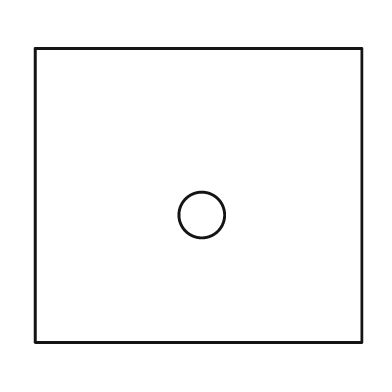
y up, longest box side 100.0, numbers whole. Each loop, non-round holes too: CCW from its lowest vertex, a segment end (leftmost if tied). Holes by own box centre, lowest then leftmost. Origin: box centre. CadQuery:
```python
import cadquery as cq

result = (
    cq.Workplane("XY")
    .moveTo(-50.0, -45.0)
    .lineTo(50.0, -45.0)
    .lineTo(50.0, 45.0)
    .lineTo(-50.0, 45.0)
    .close()
    .moveTo(1.0, -6.0)
    .circle(7.0)
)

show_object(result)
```